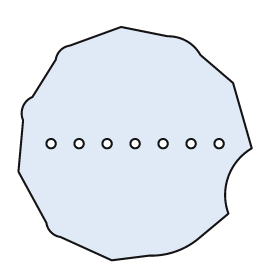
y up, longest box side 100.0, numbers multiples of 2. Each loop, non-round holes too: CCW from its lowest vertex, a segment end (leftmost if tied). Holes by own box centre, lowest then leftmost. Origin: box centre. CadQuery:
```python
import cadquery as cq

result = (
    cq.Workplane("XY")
    .moveTo(-10.0, -50.0)
    .lineTo(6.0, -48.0)
    .threePointArc((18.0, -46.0), (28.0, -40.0))
    .lineTo(40.0, -30.0)
    .threePointArc((40.0, -14.0), (50.0, -2.0))
    .lineTo(42.0, 26.0)
    .lineTo(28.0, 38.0)
    .threePointArc((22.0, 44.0), (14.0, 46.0))
    .lineTo(-6.0, 50.0)
    .lineTo(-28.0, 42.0)
    .threePointArc((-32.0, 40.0), (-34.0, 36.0))
    .lineTo(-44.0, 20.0)
    .threePointArc((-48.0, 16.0), (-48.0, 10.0))
    .lineTo(-50.0, -12.0)
    .lineTo(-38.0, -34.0)
    .threePointArc((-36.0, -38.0), (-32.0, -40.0))
    .close()
    .moveTo(-36.0, 0.0)
    .circle(2.0)
    .moveTo(-24.0, 0.0)
    .circle(2.0)
    .moveTo(-12.0, 0.0)
    .circle(2.0)
    .moveTo(0.0, 0.0)
    .circle(2.0)
    .moveTo(12.0, 0.0)
    .circle(2.0)
    .moveTo(24.0, 0.0)
    .circle(2.0)
    .moveTo(36.0, 0.0)
    .circle(2.0)
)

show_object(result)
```